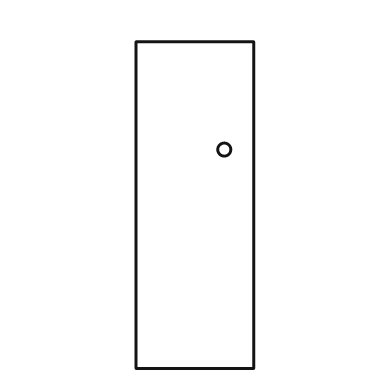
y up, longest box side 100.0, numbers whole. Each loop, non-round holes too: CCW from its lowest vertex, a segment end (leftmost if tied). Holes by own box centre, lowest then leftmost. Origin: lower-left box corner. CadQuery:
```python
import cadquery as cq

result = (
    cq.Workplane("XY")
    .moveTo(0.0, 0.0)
    .lineTo(36.0, 0.0)
    .lineTo(36.0, 100.0)
    .lineTo(0.0, 100.0)
    .close()
    .moveTo(27.0, 67.0)
    .circle(2.0)
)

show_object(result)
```